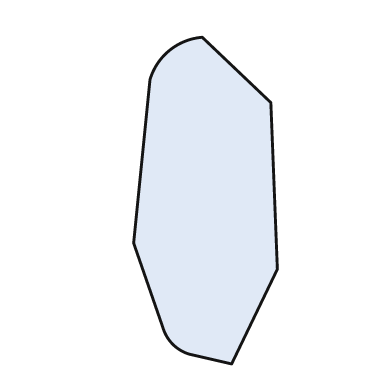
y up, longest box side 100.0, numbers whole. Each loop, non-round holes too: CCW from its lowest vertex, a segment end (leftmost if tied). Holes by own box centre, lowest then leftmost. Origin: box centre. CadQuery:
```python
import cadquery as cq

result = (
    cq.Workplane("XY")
    .moveTo(8.0, -50.0)
    .lineTo(22.0, -21.0)
    .lineTo(20.0, 30.0)
    .lineTo(-1.0, 50.0)
    .threePointArc((-11.0, 46.0), (-17.0, 37.0))
    .lineTo(-22.0, -13.0)
    .lineTo(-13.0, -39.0)
    .threePointArc((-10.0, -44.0), (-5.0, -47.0))
    .close()
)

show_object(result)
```